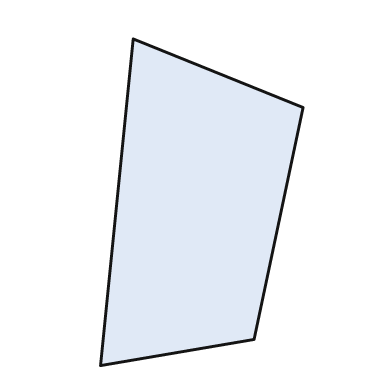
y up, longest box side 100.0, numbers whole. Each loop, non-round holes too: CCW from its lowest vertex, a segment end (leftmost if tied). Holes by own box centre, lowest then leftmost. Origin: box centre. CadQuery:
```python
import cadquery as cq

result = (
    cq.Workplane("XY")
    .moveTo(-31.0, -50.0)
    .lineTo(16.0, -42.0)
    .lineTo(31.0, 29.0)
    .lineTo(-21.0, 50.0)
    .close()
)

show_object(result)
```